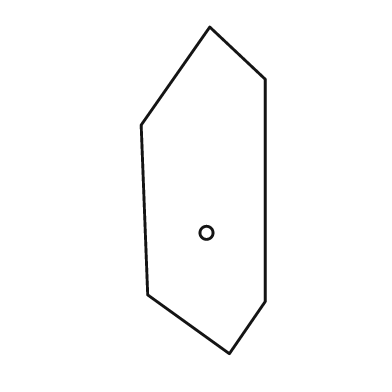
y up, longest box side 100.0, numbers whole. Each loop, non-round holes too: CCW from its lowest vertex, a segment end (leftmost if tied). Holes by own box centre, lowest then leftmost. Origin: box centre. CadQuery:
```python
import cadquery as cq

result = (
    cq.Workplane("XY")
    .moveTo(8.0, -50.0)
    .lineTo(19.0, -34.0)
    .lineTo(19.0, 34.0)
    .lineTo(2.0, 50.0)
    .lineTo(-19.0, 20.0)
    .lineTo(-17.0, -32.0)
    .close()
    .moveTo(1.0, -13.0)
    .circle(2.0)
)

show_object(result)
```